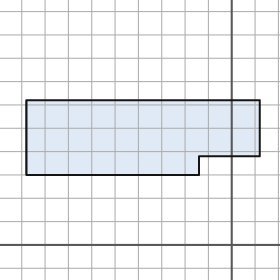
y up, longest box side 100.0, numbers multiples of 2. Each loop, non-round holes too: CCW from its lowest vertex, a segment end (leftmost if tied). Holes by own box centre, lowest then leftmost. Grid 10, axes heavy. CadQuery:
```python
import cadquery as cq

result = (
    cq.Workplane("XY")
    .moveTo(-88.0, 30.0)
    .lineTo(-14.0, 30.0)
    .lineTo(-14.0, 38.0)
    .lineTo(12.0, 38.0)
    .lineTo(12.0, 62.0)
    .lineTo(-88.0, 62.0)
    .close()
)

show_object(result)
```